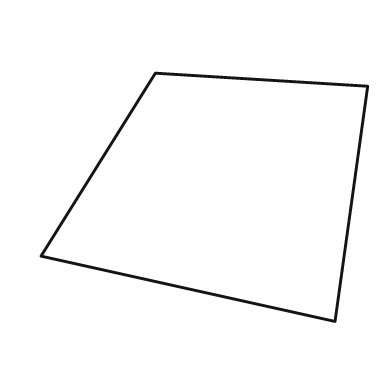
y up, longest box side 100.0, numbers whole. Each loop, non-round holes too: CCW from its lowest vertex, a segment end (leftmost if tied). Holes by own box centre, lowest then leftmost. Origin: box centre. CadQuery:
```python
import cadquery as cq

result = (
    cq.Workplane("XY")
    .moveTo(40.0, -38.0)
    .lineTo(50.0, 34.0)
    .lineTo(-15.0, 38.0)
    .lineTo(-50.0, -18.0)
    .close()
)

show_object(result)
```